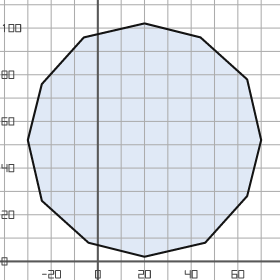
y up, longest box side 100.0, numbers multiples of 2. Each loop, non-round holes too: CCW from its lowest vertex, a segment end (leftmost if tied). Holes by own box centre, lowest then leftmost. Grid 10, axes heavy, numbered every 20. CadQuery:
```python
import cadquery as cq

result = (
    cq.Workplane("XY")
    .moveTo(20.0, 2.0)
    .lineTo(46.0, 8.0)
    .lineTo(64.0, 28.0)
    .lineTo(70.0, 52.0)
    .lineTo(64.0, 78.0)
    .lineTo(44.0, 96.0)
    .lineTo(20.0, 102.0)
    .lineTo(-6.0, 96.0)
    .lineTo(-24.0, 76.0)
    .lineTo(-30.0, 52.0)
    .lineTo(-24.0, 26.0)
    .lineTo(-4.0, 8.0)
    .close()
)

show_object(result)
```